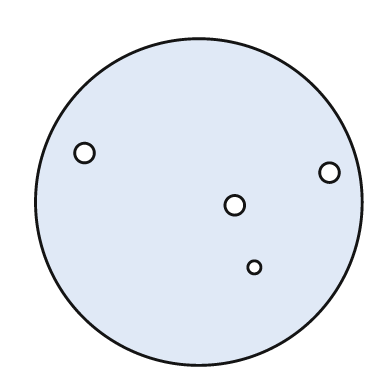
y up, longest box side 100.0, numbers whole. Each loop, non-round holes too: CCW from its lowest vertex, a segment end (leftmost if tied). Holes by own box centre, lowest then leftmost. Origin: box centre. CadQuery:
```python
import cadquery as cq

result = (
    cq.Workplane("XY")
    .moveTo(0.0, 0.0)
    .circle(50.0)
    .moveTo(17.0, -20.0)
    .circle(2.0)
    .moveTo(11.0, -1.0)
    .circle(3.0)
    .moveTo(40.0, 9.0)
    .circle(3.0)
    .moveTo(-35.0, 15.0)
    .circle(3.0)
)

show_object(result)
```